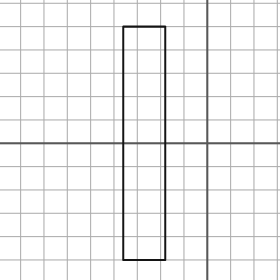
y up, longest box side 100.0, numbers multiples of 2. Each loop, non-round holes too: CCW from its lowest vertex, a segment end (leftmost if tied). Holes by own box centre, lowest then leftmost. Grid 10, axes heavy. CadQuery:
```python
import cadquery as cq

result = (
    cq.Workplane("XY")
    .moveTo(-36.0, -50.0)
    .lineTo(-18.0, -50.0)
    .lineTo(-18.0, 50.0)
    .lineTo(-36.0, 50.0)
    .close()
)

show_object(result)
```